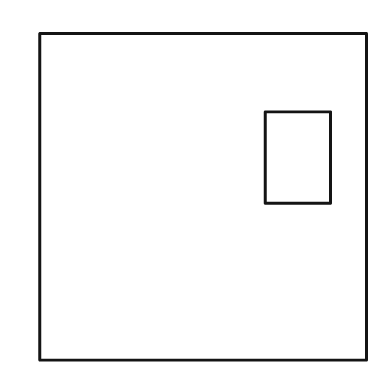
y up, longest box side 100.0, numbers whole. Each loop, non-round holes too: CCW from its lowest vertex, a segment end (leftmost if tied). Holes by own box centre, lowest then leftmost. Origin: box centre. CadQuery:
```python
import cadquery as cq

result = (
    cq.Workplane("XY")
    .moveTo(-50.0, -50.0)
    .lineTo(50.0, -50.0)
    .lineTo(50.0, 50.0)
    .lineTo(-50.0, 50.0)
    .close()
    .moveTo(19.0, -2.0)
    .lineTo(39.0, -2.0)
    .lineTo(39.0, 26.0)
    .lineTo(19.0, 26.0)
    .close()
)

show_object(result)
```